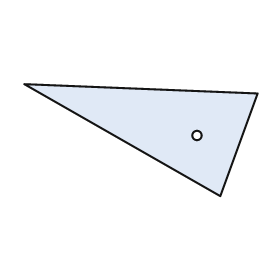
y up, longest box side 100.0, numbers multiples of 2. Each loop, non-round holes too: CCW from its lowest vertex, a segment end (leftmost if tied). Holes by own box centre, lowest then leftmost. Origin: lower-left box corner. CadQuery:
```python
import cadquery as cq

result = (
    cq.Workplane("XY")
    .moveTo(84.0, 0.0)
    .lineTo(100.0, 44.0)
    .lineTo(0.0, 48.0)
    .close()
    .moveTo(74.0, 26.0)
    .circle(2.0)
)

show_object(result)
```